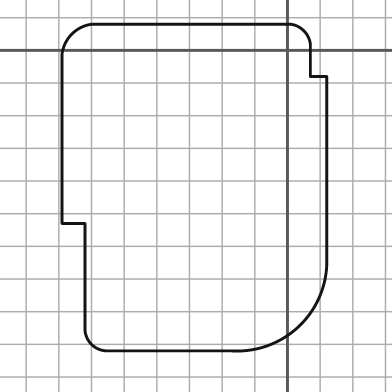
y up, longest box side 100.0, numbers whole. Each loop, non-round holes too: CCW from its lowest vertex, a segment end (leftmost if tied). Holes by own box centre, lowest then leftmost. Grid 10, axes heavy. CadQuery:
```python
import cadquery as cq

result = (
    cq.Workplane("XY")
    .moveTo(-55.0, -92.0)
    .lineTo(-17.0, -92.0)
    .threePointArc((4.0, -84.0), (12.0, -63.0))
    .lineTo(12.0, -8.0)
    .lineTo(7.0, -8.0)
    .lineTo(7.0, 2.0)
    .threePointArc((5.0, 6.0), (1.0, 8.0))
    .lineTo(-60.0, 8.0)
    .threePointArc((-66.0, 5.0), (-69.0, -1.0))
    .lineTo(-69.0, -53.0)
    .lineTo(-62.0, -53.0)
    .lineTo(-62.0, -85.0)
    .threePointArc((-60.0, -90.0), (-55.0, -92.0))
    .close()
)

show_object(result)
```